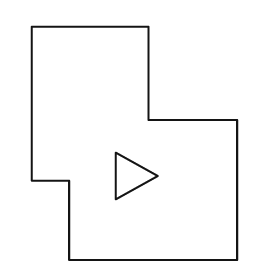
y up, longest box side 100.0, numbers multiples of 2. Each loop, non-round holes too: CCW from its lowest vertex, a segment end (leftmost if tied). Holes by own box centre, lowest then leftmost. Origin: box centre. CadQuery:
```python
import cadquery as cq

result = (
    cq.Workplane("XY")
    .moveTo(-28.0, -50.0)
    .lineTo(44.0, -50.0)
    .lineTo(44.0, 10.0)
    .lineTo(6.0, 10.0)
    .lineTo(6.0, 50.0)
    .lineTo(-44.0, 50.0)
    .lineTo(-44.0, -16.0)
    .lineTo(-28.0, -16.0)
    .close()
    .moveTo(-8.0, -24.0)
    .lineTo(10.0, -14.0)
    .lineTo(-8.0, -4.0)
    .close()
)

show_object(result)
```